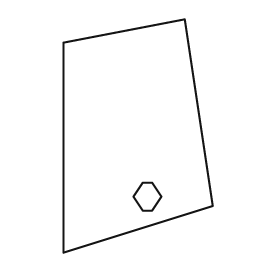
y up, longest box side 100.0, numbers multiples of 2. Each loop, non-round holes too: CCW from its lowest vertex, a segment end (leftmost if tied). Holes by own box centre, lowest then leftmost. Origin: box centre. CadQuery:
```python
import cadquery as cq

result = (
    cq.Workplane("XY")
    .moveTo(-32.0, -50.0)
    .lineTo(32.0, -30.0)
    .lineTo(20.0, 50.0)
    .lineTo(-32.0, 40.0)
    .close()
    .moveTo(2.0, -32.0)
    .lineTo(6.0, -32.0)
    .lineTo(10.0, -26.0)
    .lineTo(6.0, -20.0)
    .lineTo(2.0, -20.0)
    .lineTo(-2.0, -26.0)
    .close()
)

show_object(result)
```